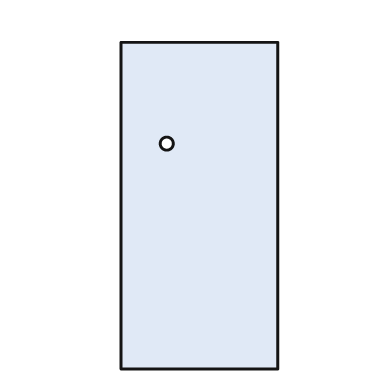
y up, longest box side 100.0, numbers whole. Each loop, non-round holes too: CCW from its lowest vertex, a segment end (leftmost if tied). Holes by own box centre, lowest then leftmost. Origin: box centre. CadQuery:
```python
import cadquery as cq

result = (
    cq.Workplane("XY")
    .moveTo(-24.0, -50.0)
    .lineTo(24.0, -50.0)
    .lineTo(24.0, 50.0)
    .lineTo(-24.0, 50.0)
    .close()
    .moveTo(-10.0, 19.0)
    .circle(2.0)
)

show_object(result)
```